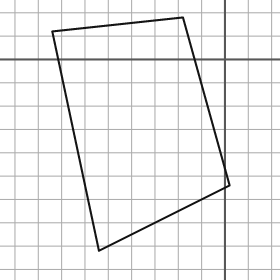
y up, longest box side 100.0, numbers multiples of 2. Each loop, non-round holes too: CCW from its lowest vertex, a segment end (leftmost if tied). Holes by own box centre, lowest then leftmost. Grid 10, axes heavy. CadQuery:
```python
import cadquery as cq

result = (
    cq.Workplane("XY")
    .moveTo(-54.0, -82.0)
    .lineTo(2.0, -54.0)
    .lineTo(-18.0, 18.0)
    .lineTo(-74.0, 12.0)
    .close()
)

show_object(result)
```